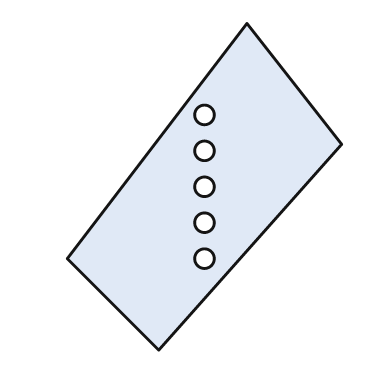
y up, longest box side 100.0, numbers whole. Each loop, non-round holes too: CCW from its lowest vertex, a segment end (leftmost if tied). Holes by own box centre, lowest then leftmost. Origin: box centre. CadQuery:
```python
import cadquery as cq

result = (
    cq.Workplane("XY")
    .moveTo(-14.0, -50.0)
    .lineTo(42.0, 13.0)
    .lineTo(13.0, 50.0)
    .lineTo(-42.0, -22.0)
    .close()
    .moveTo(0.0, -22.0)
    .circle(3.0)
    .moveTo(0.0, -11.0)
    .circle(3.0)
    .moveTo(0.0, 0.0)
    .circle(3.0)
    .moveTo(0.0, 11.0)
    .circle(3.0)
    .moveTo(0.0, 22.0)
    .circle(3.0)
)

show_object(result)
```